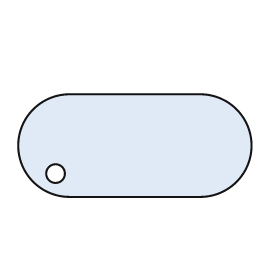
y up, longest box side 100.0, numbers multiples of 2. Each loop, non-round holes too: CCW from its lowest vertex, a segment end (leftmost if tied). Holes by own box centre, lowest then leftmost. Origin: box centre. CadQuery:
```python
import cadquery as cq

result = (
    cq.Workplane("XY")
    .moveTo(-28.0, -22.0)
    .lineTo(28.0, -22.0)
    .threePointArc((50.0, 0.0), (28.0, 22.0))
    .lineTo(-28.0, 22.0)
    .threePointArc((-50.0, 0.0), (-28.0, -22.0))
    .close()
    .moveTo(-34.0, -12.0)
    .circle(4.0)
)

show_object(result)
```